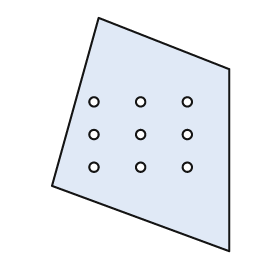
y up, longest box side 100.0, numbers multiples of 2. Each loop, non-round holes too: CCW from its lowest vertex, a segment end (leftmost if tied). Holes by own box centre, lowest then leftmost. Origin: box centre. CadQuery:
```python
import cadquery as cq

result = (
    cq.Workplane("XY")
    .moveTo(38.0, -50.0)
    .lineTo(38.0, 28.0)
    .lineTo(-18.0, 50.0)
    .lineTo(-38.0, -22.0)
    .close()
    .moveTo(-20.0, -14.0)
    .circle(2.0)
    .moveTo(0.0, -14.0)
    .circle(2.0)
    .moveTo(20.0, -14.0)
    .circle(2.0)
    .moveTo(-20.0, 0.0)
    .circle(2.0)
    .moveTo(0.0, 0.0)
    .circle(2.0)
    .moveTo(20.0, 0.0)
    .circle(2.0)
    .moveTo(-20.0, 14.0)
    .circle(2.0)
    .moveTo(0.0, 14.0)
    .circle(2.0)
    .moveTo(20.0, 14.0)
    .circle(2.0)
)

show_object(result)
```